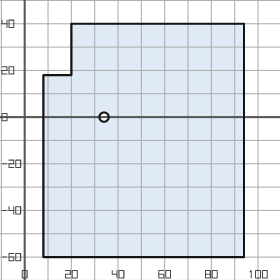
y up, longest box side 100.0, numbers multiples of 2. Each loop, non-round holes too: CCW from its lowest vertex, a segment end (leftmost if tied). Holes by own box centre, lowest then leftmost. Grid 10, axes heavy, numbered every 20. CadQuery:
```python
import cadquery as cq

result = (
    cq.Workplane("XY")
    .moveTo(8.0, -60.0)
    .lineTo(94.0, -60.0)
    .lineTo(94.0, 40.0)
    .lineTo(20.0, 40.0)
    .lineTo(20.0, 18.0)
    .lineTo(8.0, 18.0)
    .close()
    .moveTo(34.0, 0.0)
    .circle(2.0)
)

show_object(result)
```